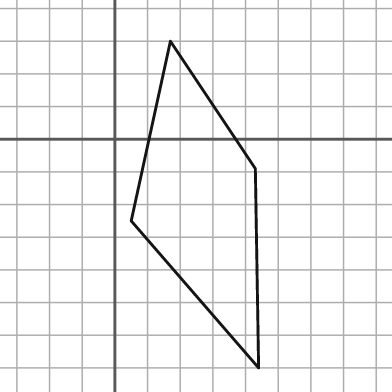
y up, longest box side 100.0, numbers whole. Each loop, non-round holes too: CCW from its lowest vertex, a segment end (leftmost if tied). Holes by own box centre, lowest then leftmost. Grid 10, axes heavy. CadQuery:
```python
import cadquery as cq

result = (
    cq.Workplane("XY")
    .moveTo(44.0, -70.0)
    .lineTo(43.0, -9.0)
    .lineTo(17.0, 30.0)
    .lineTo(5.0, -25.0)
    .close()
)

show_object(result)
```